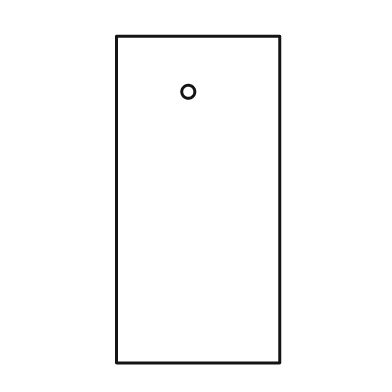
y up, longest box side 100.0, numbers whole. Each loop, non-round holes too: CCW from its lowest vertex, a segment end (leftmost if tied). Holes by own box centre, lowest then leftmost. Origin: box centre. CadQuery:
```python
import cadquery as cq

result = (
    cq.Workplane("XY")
    .moveTo(-25.0, -50.0)
    .lineTo(25.0, -50.0)
    .lineTo(25.0, 50.0)
    .lineTo(-25.0, 50.0)
    .close()
    .moveTo(-3.0, 33.0)
    .circle(2.0)
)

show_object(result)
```